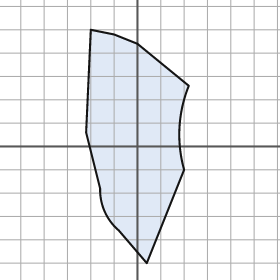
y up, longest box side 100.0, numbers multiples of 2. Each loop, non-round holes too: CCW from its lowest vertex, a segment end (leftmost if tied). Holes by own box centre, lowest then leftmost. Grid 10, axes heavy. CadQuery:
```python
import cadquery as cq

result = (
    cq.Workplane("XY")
    .moveTo(4.0, -50.0)
    .lineTo(20.0, -10.0)
    .threePointArc((18.0, 8.0), (22.0, 26.0))
    .lineTo(0.0, 44.0)
    .lineTo(-10.0, 48.0)
    .lineTo(-20.0, 50.0)
    .lineTo(-22.0, 6.0)
    .lineTo(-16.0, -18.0)
    .threePointArc((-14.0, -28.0), (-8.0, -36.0))
    .close()
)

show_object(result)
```